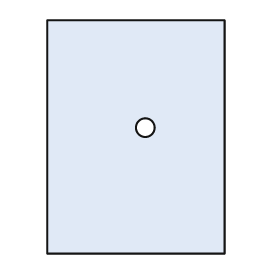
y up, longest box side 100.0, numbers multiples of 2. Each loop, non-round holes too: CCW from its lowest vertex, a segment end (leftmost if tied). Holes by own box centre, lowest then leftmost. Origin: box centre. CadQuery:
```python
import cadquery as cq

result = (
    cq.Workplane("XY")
    .moveTo(-38.0, -50.0)
    .lineTo(38.0, -50.0)
    .lineTo(38.0, 50.0)
    .lineTo(-38.0, 50.0)
    .close()
    .moveTo(4.0, 4.0)
    .circle(4.0)
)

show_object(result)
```